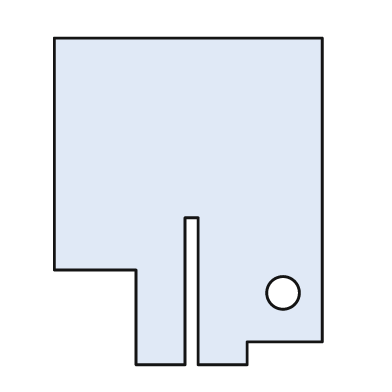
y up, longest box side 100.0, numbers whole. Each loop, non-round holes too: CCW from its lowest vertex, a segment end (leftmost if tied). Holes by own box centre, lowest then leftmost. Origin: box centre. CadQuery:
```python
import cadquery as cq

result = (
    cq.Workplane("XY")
    .moveTo(-16.0, -50.0)
    .lineTo(-1.0, -50.0)
    .lineTo(-1.0, -5.0)
    .lineTo(3.0, -5.0)
    .lineTo(3.0, -50.0)
    .lineTo(18.0, -50.0)
    .lineTo(18.0, -43.0)
    .lineTo(41.0, -43.0)
    .lineTo(41.0, 50.0)
    .lineTo(-41.0, 50.0)
    .lineTo(-41.0, -21.0)
    .lineTo(-16.0, -21.0)
    .close()
    .moveTo(29.0, -28.0)
    .circle(5.0)
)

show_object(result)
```